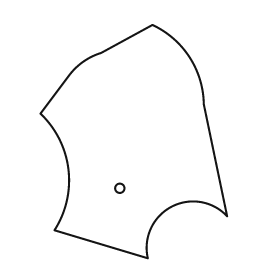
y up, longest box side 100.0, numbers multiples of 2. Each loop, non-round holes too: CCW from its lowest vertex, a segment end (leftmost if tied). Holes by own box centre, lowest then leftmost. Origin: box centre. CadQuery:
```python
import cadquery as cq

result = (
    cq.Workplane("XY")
    .moveTo(6.0, -50.0)
    .threePointArc((16.0, -28.0), (40.0, -32.0))
    .lineTo(30.0, 16.0)
    .threePointArc((24.0, 36.0), (8.0, 50.0))
    .lineTo(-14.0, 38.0)
    .threePointArc((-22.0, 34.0), (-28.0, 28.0))
    .lineTo(-40.0, 12.0)
    .threePointArc((-28.0, -12.0), (-34.0, -38.0))
    .close()
    .moveTo(-6.0, -20.0)
    .circle(2.0)
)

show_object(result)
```